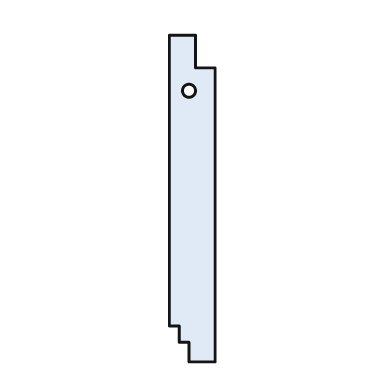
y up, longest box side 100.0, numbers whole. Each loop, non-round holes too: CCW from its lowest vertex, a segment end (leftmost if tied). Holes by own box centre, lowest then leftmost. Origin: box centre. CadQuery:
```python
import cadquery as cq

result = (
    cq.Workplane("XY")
    .moveTo(-1.0, -50.0)
    .lineTo(7.0, -50.0)
    .lineTo(7.0, 40.0)
    .lineTo(1.0, 40.0)
    .lineTo(1.0, 50.0)
    .lineTo(-7.0, 50.0)
    .lineTo(-7.0, -39.0)
    .lineTo(-4.0, -39.0)
    .lineTo(-4.0, -44.0)
    .lineTo(-1.0, -44.0)
    .close()
    .moveTo(-1.0, 33.0)
    .circle(2.0)
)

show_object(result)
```